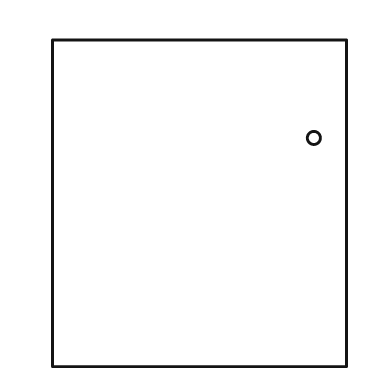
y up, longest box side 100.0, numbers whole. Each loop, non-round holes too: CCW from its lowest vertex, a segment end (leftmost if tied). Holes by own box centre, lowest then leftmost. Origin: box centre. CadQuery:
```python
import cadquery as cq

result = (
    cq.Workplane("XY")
    .moveTo(-45.0, -50.0)
    .lineTo(45.0, -50.0)
    .lineTo(45.0, 50.0)
    .lineTo(-45.0, 50.0)
    .close()
    .moveTo(35.0, 20.0)
    .circle(2.0)
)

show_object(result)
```